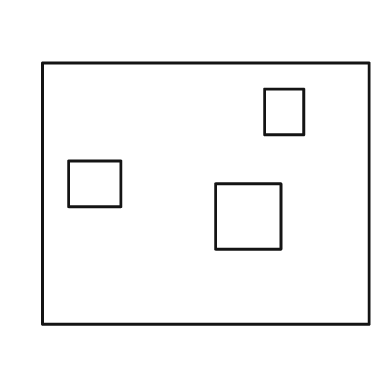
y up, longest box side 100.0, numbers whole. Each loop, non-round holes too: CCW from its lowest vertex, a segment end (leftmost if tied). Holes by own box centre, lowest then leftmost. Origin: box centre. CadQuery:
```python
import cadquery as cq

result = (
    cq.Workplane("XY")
    .moveTo(-50.0, -40.0)
    .lineTo(50.0, -40.0)
    .lineTo(50.0, 40.0)
    .lineTo(-50.0, 40.0)
    .close()
    .moveTo(3.0, -17.0)
    .lineTo(23.0, -17.0)
    .lineTo(23.0, 3.0)
    .lineTo(3.0, 3.0)
    .close()
    .moveTo(-42.0, -4.0)
    .lineTo(-26.0, -4.0)
    .lineTo(-26.0, 10.0)
    .lineTo(-42.0, 10.0)
    .close()
    .moveTo(18.0, 18.0)
    .lineTo(30.0, 18.0)
    .lineTo(30.0, 32.0)
    .lineTo(18.0, 32.0)
    .close()
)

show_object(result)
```